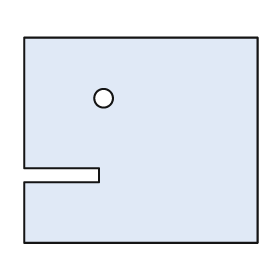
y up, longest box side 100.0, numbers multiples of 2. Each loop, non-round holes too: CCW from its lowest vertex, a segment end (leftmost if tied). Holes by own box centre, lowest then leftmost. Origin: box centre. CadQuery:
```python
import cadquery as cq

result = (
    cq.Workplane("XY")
    .moveTo(-50.0, -44.0)
    .lineTo(50.0, -44.0)
    .lineTo(50.0, 44.0)
    .lineTo(-50.0, 44.0)
    .lineTo(-50.0, -12.0)
    .lineTo(-18.0, -12.0)
    .lineTo(-18.0, -18.0)
    .lineTo(-50.0, -18.0)
    .close()
    .moveTo(-16.0, 18.0)
    .circle(4.0)
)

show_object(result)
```